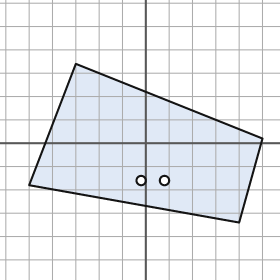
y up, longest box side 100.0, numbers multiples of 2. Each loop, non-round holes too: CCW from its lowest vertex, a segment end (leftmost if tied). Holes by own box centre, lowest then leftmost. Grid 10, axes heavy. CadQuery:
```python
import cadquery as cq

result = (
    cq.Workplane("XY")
    .moveTo(40.0, -34.0)
    .lineTo(50.0, 2.0)
    .lineTo(-30.0, 34.0)
    .lineTo(-50.0, -18.0)
    .close()
    .moveTo(-2.0, -16.0)
    .circle(2.0)
    .moveTo(8.0, -16.0)
    .circle(2.0)
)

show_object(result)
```